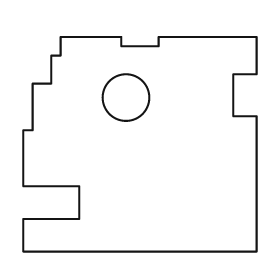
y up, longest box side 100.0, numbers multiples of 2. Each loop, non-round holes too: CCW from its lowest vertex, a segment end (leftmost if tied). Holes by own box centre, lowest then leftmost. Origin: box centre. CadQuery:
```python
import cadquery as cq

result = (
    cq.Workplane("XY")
    .moveTo(-50.0, -46.0)
    .lineTo(50.0, -46.0)
    .lineTo(50.0, 12.0)
    .lineTo(40.0, 12.0)
    .lineTo(40.0, 30.0)
    .lineTo(50.0, 30.0)
    .lineTo(50.0, 46.0)
    .lineTo(8.0, 46.0)
    .lineTo(8.0, 42.0)
    .lineTo(-8.0, 42.0)
    .lineTo(-8.0, 46.0)
    .lineTo(-34.0, 46.0)
    .lineTo(-34.0, 38.0)
    .lineTo(-38.0, 38.0)
    .lineTo(-38.0, 26.0)
    .lineTo(-46.0, 26.0)
    .lineTo(-46.0, 6.0)
    .lineTo(-50.0, 6.0)
    .lineTo(-50.0, -18.0)
    .lineTo(-26.0, -18.0)
    .lineTo(-26.0, -32.0)
    .lineTo(-50.0, -32.0)
    .close()
    .moveTo(-6.0, 20.0)
    .circle(10.0)
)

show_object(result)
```